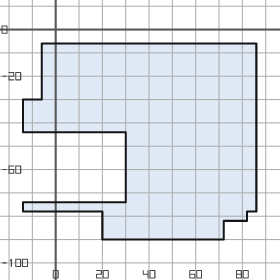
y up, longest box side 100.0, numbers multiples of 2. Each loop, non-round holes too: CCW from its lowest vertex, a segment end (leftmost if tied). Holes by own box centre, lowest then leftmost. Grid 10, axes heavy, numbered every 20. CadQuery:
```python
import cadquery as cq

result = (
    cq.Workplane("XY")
    .moveTo(20.0, -90.0)
    .lineTo(72.0, -90.0)
    .lineTo(72.0, -82.0)
    .lineTo(82.0, -82.0)
    .lineTo(82.0, -78.0)
    .lineTo(86.0, -78.0)
    .lineTo(86.0, -6.0)
    .lineTo(-6.0, -6.0)
    .lineTo(-6.0, -30.0)
    .lineTo(-14.0, -30.0)
    .lineTo(-14.0, -44.0)
    .lineTo(30.0, -44.0)
    .lineTo(30.0, -74.0)
    .lineTo(-14.0, -74.0)
    .lineTo(-14.0, -78.0)
    .lineTo(20.0, -78.0)
    .close()
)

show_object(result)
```